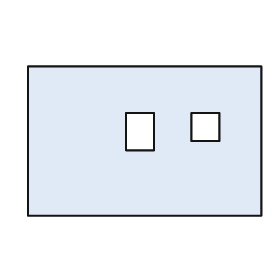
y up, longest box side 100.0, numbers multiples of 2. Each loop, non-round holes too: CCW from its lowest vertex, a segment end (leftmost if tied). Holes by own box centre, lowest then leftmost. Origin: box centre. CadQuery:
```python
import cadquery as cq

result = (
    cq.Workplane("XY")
    .moveTo(-50.0, -32.0)
    .lineTo(50.0, -32.0)
    .lineTo(50.0, 32.0)
    .lineTo(-50.0, 32.0)
    .close()
    .moveTo(-8.0, -4.0)
    .lineTo(4.0, -4.0)
    .lineTo(4.0, 12.0)
    .lineTo(-8.0, 12.0)
    .close()
    .moveTo(20.0, 0.0)
    .lineTo(32.0, 0.0)
    .lineTo(32.0, 12.0)
    .lineTo(20.0, 12.0)
    .close()
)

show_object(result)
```